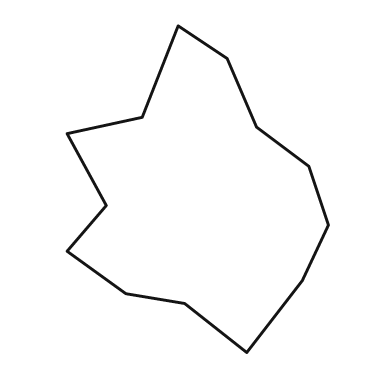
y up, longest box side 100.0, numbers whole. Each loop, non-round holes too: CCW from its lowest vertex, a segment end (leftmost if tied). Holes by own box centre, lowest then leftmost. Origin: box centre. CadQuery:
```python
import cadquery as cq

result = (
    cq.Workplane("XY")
    .moveTo(15.0, -50.0)
    .lineTo(32.0, -28.0)
    .lineTo(40.0, -11.0)
    .lineTo(34.0, 7.0)
    .lineTo(18.0, 19.0)
    .lineTo(9.0, 40.0)
    .lineTo(-6.0, 50.0)
    .lineTo(-17.0, 22.0)
    .lineTo(-40.0, 17.0)
    .lineTo(-28.0, -5.0)
    .lineTo(-40.0, -19.0)
    .lineTo(-22.0, -32.0)
    .lineTo(-4.0, -35.0)
    .close()
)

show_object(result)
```